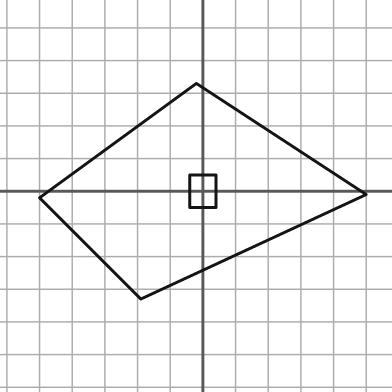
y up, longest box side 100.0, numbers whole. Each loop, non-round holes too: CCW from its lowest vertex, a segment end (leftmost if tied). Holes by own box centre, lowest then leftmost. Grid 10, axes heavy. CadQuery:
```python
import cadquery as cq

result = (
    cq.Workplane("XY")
    .moveTo(-19.0, -33.0)
    .lineTo(50.0, -1.0)
    .lineTo(-2.0, 33.0)
    .lineTo(-50.0, -2.0)
    .close()
    .moveTo(-4.0, -5.0)
    .lineTo(4.0, -5.0)
    .lineTo(4.0, 5.0)
    .lineTo(-4.0, 5.0)
    .close()
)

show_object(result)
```